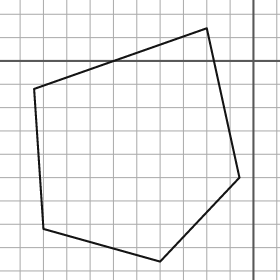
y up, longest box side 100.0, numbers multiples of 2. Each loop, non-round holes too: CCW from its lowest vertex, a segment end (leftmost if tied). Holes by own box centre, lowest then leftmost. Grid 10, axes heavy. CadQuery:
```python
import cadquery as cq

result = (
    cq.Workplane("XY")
    .moveTo(-40.0, -86.0)
    .lineTo(-6.0, -50.0)
    .lineTo(-20.0, 14.0)
    .lineTo(-94.0, -12.0)
    .lineTo(-90.0, -72.0)
    .close()
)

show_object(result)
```